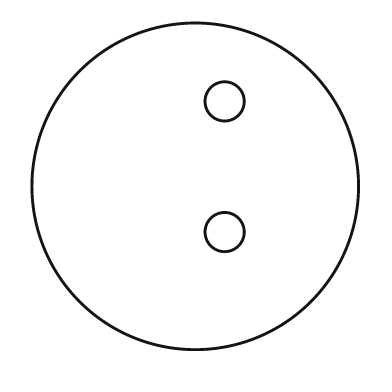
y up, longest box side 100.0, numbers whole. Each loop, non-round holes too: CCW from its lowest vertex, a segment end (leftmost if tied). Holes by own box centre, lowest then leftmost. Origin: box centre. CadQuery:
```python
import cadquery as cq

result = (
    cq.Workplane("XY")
    .moveTo(0.0, 0.0)
    .circle(50.0)
    .moveTo(9.0, -14.0)
    .circle(6.0)
    .moveTo(9.0, 26.0)
    .circle(6.0)
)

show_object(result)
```